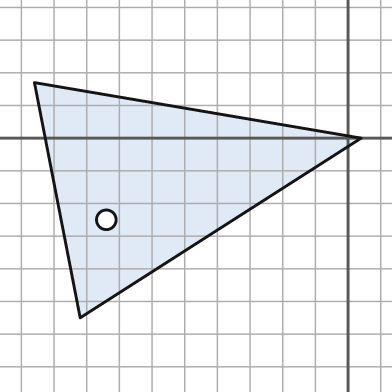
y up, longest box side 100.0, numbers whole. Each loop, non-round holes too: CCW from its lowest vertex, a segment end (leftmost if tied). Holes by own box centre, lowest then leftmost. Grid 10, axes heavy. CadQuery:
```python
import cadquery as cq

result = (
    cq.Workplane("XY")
    .moveTo(-82.0, -55.0)
    .lineTo(4.0, 0.0)
    .lineTo(-96.0, 17.0)
    .close()
    .moveTo(-74.0, -25.0)
    .circle(3.0)
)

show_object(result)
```